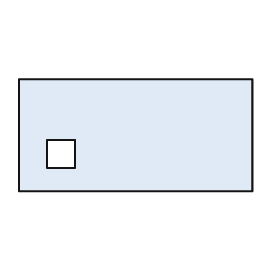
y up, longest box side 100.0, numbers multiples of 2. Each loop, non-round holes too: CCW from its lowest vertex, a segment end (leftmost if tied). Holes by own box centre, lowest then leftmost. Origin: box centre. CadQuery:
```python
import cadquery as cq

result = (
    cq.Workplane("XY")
    .moveTo(-50.0, -24.0)
    .lineTo(50.0, -24.0)
    .lineTo(50.0, 24.0)
    .lineTo(-50.0, 24.0)
    .close()
    .moveTo(-38.0, -14.0)
    .lineTo(-26.0, -14.0)
    .lineTo(-26.0, -2.0)
    .lineTo(-38.0, -2.0)
    .close()
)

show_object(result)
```